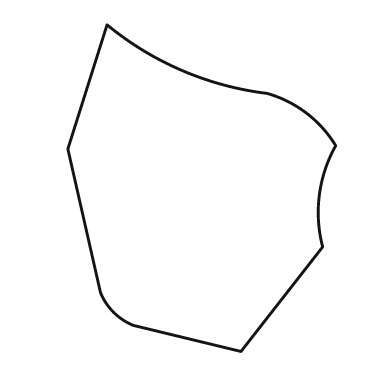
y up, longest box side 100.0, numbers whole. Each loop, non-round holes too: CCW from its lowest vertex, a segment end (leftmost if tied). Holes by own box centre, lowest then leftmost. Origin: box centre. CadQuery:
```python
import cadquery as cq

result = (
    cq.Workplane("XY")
    .moveTo(12.0, -50.0)
    .lineTo(37.0, -18.0)
    .threePointArc((36.0, -2.0), (41.0, 13.0))
    .threePointArc((32.0, 23.0), (20.0, 29.0))
    .threePointArc((-6.0, 36.0), (-29.0, 50.0))
    .lineTo(-41.0, 12.0)
    .lineTo(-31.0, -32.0)
    .threePointArc((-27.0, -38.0), (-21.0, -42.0))
    .close()
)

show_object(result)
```